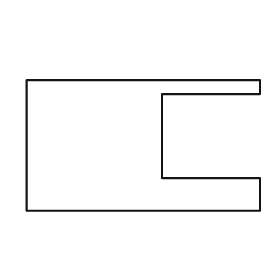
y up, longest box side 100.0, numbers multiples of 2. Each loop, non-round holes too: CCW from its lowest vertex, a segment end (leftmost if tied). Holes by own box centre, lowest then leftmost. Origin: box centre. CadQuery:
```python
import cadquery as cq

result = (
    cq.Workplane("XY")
    .moveTo(-50.0, -28.0)
    .lineTo(50.0, -28.0)
    .lineTo(50.0, -14.0)
    .lineTo(8.0, -14.0)
    .lineTo(8.0, 22.0)
    .lineTo(50.0, 22.0)
    .lineTo(50.0, 28.0)
    .lineTo(-50.0, 28.0)
    .close()
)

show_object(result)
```